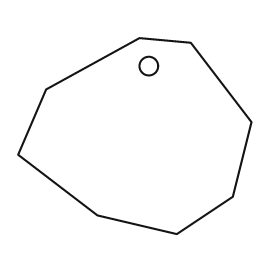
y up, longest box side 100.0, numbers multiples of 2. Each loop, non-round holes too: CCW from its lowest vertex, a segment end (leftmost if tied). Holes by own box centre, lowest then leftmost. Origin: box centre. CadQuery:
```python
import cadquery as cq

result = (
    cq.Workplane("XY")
    .moveTo(18.0, -42.0)
    .lineTo(42.0, -26.0)
    .lineTo(50.0, 6.0)
    .lineTo(24.0, 40.0)
    .lineTo(2.0, 42.0)
    .lineTo(-38.0, 20.0)
    .lineTo(-50.0, -8.0)
    .lineTo(-16.0, -34.0)
    .close()
    .moveTo(6.0, 30.0)
    .circle(4.0)
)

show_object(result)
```